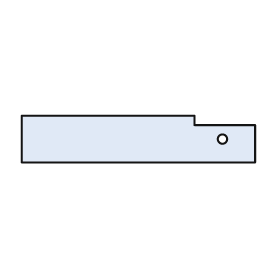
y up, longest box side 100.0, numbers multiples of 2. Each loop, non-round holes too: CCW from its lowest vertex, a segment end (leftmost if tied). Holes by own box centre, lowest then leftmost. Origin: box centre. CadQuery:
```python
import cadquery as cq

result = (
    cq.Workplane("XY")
    .moveTo(-50.0, -10.0)
    .lineTo(50.0, -10.0)
    .lineTo(50.0, 6.0)
    .lineTo(24.0, 6.0)
    .lineTo(24.0, 10.0)
    .lineTo(-50.0, 10.0)
    .close()
    .moveTo(36.0, 0.0)
    .circle(2.0)
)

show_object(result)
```